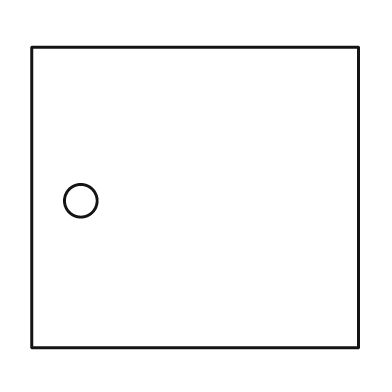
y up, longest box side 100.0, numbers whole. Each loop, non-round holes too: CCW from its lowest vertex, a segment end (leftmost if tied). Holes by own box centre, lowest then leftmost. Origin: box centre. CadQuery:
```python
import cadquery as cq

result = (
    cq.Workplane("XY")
    .moveTo(-50.0, -46.0)
    .lineTo(50.0, -46.0)
    .lineTo(50.0, 46.0)
    .lineTo(-50.0, 46.0)
    .close()
    .moveTo(-35.0, -1.0)
    .circle(5.0)
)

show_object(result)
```